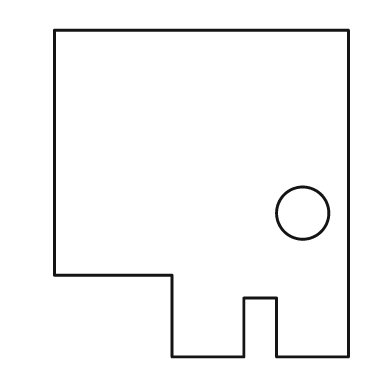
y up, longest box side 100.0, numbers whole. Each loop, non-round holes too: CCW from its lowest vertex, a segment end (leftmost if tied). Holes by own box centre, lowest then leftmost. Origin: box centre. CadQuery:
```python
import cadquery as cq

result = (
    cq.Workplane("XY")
    .moveTo(-9.0, -50.0)
    .lineTo(13.0, -50.0)
    .lineTo(13.0, -32.0)
    .lineTo(23.0, -32.0)
    .lineTo(23.0, -50.0)
    .lineTo(45.0, -50.0)
    .lineTo(45.0, 50.0)
    .lineTo(-45.0, 50.0)
    .lineTo(-45.0, -25.0)
    .lineTo(-9.0, -25.0)
    .close()
    .moveTo(31.0, -6.0)
    .circle(8.0)
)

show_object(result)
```